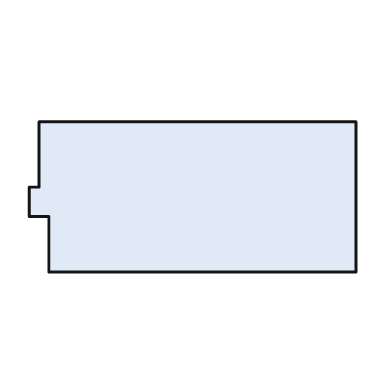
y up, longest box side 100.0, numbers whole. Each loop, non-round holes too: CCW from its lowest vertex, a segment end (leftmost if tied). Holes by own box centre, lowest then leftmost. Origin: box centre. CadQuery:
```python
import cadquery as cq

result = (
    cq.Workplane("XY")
    .moveTo(-44.0, -23.0)
    .lineTo(50.0, -23.0)
    .lineTo(50.0, 23.0)
    .lineTo(-47.0, 23.0)
    .lineTo(-47.0, 3.0)
    .lineTo(-50.0, 3.0)
    .lineTo(-50.0, -6.0)
    .lineTo(-44.0, -6.0)
    .close()
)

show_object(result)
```